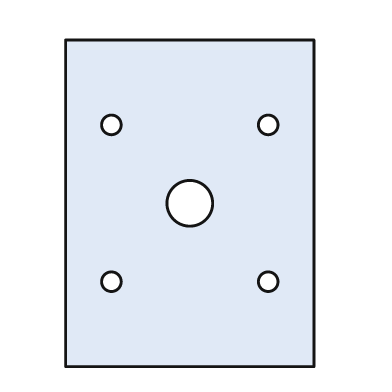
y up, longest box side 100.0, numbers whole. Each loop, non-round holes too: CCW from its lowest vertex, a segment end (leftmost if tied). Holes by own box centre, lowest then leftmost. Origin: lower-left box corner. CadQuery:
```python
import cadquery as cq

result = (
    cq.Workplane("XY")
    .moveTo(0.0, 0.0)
    .lineTo(76.0, 0.0)
    .lineTo(76.0, 100.0)
    .lineTo(0.0, 100.0)
    .close()
    .moveTo(14.0, 26.0)
    .circle(3.0)
    .moveTo(62.0, 26.0)
    .circle(3.0)
    .moveTo(38.0, 50.0)
    .circle(7.0)
    .moveTo(14.0, 74.0)
    .circle(3.0)
    .moveTo(62.0, 74.0)
    .circle(3.0)
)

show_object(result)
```